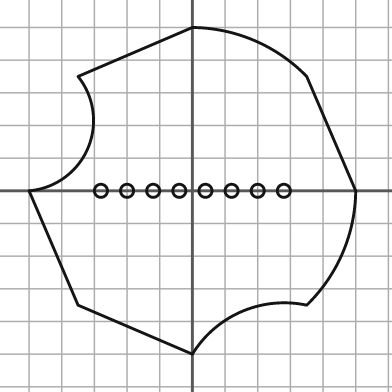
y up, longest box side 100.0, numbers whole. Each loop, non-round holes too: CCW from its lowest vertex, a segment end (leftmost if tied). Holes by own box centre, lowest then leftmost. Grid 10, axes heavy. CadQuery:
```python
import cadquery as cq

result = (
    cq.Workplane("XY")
    .moveTo(0.0, -50.0)
    .threePointArc((15.0, -37.0), (35.0, -35.0))
    .threePointArc((46.0, -19.0), (50.0, 0.0))
    .lineTo(35.0, 35.0)
    .threePointArc((19.0, 46.0), (0.0, 50.0))
    .lineTo(-35.0, 35.0)
    .threePointArc((-32.0, 13.0), (-50.0, 0.0))
    .lineTo(-35.0, -35.0)
    .close()
    .moveTo(-28.0, 0.0)
    .circle(2.0)
    .moveTo(-20.0, 0.0)
    .circle(2.0)
    .moveTo(-12.0, 0.0)
    .circle(2.0)
    .moveTo(-4.0, 0.0)
    .circle(2.0)
    .moveTo(4.0, 0.0)
    .circle(2.0)
    .moveTo(12.0, 0.0)
    .circle(2.0)
    .moveTo(20.0, 0.0)
    .circle(2.0)
    .moveTo(28.0, 0.0)
    .circle(2.0)
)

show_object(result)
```